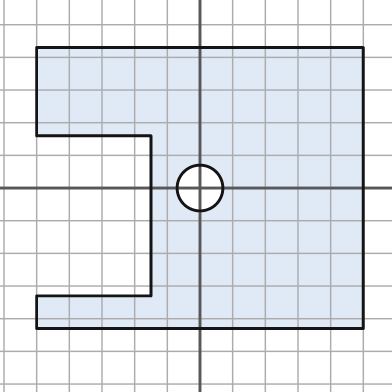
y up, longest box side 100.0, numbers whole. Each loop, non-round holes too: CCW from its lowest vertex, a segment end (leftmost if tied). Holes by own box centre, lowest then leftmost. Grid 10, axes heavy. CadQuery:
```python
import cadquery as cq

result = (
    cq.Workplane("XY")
    .moveTo(-50.0, -43.0)
    .lineTo(50.0, -43.0)
    .lineTo(50.0, 43.0)
    .lineTo(-50.0, 43.0)
    .lineTo(-50.0, 16.0)
    .lineTo(-15.0, 16.0)
    .lineTo(-15.0, -33.0)
    .lineTo(-50.0, -33.0)
    .close()
    .moveTo(0.0, 0.0)
    .circle(7.0)
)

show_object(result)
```